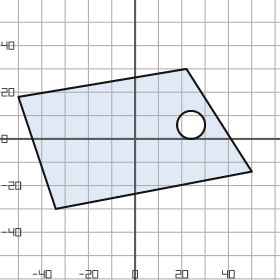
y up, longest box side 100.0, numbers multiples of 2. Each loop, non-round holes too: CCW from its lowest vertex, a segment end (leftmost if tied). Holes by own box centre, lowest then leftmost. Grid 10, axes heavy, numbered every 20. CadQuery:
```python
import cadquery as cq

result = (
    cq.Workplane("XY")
    .moveTo(-34.0, -30.0)
    .lineTo(50.0, -14.0)
    .lineTo(22.0, 30.0)
    .lineTo(-50.0, 18.0)
    .close()
    .moveTo(24.0, 6.0)
    .circle(6.0)
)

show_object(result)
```